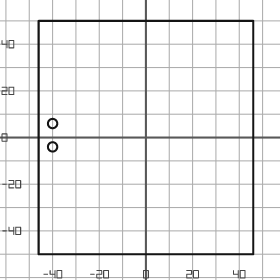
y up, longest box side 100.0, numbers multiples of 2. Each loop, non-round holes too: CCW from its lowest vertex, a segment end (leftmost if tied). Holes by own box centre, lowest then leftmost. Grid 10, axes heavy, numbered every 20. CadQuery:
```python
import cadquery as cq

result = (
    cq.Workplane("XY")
    .moveTo(-46.0, -50.0)
    .lineTo(46.0, -50.0)
    .lineTo(46.0, 50.0)
    .lineTo(-46.0, 50.0)
    .close()
    .moveTo(-40.0, -4.0)
    .circle(2.0)
    .moveTo(-40.0, 6.0)
    .circle(2.0)
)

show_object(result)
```